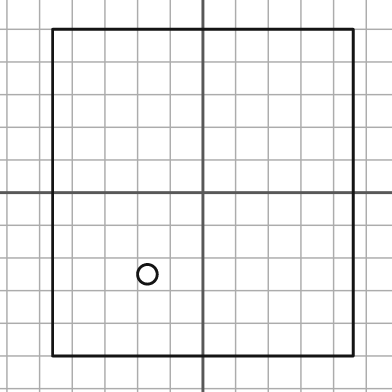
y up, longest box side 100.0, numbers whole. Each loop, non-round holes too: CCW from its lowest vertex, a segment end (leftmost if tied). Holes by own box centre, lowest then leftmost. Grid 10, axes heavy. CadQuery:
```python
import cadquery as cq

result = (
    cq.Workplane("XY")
    .moveTo(-46.0, -50.0)
    .lineTo(46.0, -50.0)
    .lineTo(46.0, 50.0)
    .lineTo(-46.0, 50.0)
    .close()
    .moveTo(-17.0, -25.0)
    .circle(3.0)
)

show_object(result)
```